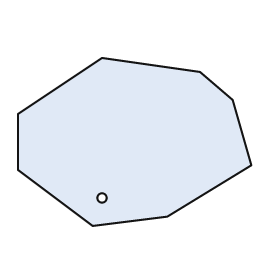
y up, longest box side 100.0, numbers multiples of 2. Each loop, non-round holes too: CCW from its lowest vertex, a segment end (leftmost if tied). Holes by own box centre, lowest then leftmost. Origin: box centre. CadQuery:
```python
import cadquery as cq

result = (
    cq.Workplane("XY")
    .moveTo(-18.0, -36.0)
    .lineTo(14.0, -32.0)
    .lineTo(50.0, -10.0)
    .lineTo(42.0, 18.0)
    .lineTo(28.0, 30.0)
    .lineTo(-14.0, 36.0)
    .lineTo(-50.0, 12.0)
    .lineTo(-50.0, -12.0)
    .close()
    .moveTo(-14.0, -24.0)
    .circle(2.0)
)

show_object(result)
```